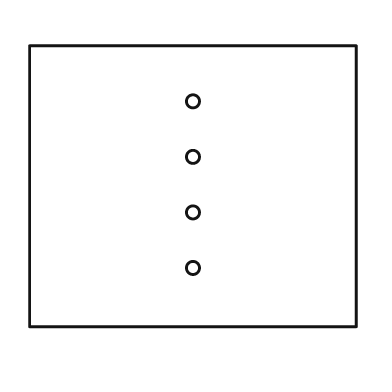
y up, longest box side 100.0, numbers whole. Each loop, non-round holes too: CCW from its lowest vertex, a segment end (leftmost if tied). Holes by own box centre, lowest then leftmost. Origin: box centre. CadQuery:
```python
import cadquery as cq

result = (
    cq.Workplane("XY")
    .moveTo(-50.0, -43.0)
    .lineTo(50.0, -43.0)
    .lineTo(50.0, 43.0)
    .lineTo(-50.0, 43.0)
    .close()
    .moveTo(0.0, -25.0)
    .circle(2.0)
    .moveTo(0.0, -8.0)
    .circle(2.0)
    .moveTo(0.0, 9.0)
    .circle(2.0)
    .moveTo(0.0, 26.0)
    .circle(2.0)
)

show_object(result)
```